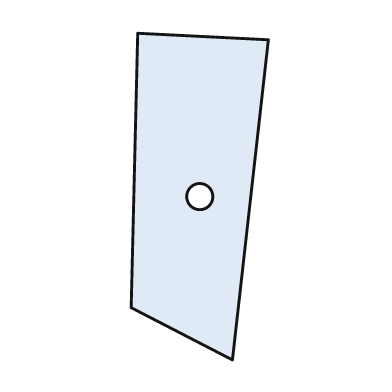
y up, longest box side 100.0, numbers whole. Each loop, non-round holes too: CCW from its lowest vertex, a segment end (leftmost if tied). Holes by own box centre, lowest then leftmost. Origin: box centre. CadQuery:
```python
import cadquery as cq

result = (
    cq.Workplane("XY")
    .moveTo(10.0, -50.0)
    .lineTo(21.0, 48.0)
    .lineTo(-19.0, 50.0)
    .lineTo(-21.0, -34.0)
    .close()
    .moveTo(0.0, 0.0)
    .circle(4.0)
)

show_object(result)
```